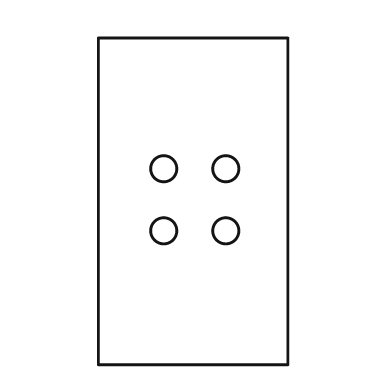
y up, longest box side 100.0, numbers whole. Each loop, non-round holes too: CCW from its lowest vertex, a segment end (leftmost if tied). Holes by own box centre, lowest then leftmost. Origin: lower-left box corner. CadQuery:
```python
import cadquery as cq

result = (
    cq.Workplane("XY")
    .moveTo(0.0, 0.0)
    .lineTo(58.0, 0.0)
    .lineTo(58.0, 100.0)
    .lineTo(0.0, 100.0)
    .close()
    .moveTo(20.0, 41.0)
    .circle(4.0)
    .moveTo(39.0, 41.0)
    .circle(4.0)
    .moveTo(20.0, 60.0)
    .circle(4.0)
    .moveTo(39.0, 60.0)
    .circle(4.0)
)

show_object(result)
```